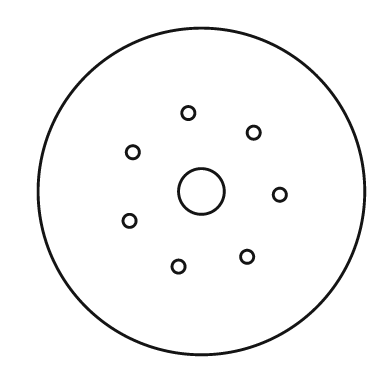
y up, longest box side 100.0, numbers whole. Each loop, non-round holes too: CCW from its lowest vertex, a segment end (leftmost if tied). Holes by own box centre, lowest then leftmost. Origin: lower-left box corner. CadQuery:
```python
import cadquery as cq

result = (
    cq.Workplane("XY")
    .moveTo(50.0, 50.0)
    .circle(50.0)
    .moveTo(43.0, 27.0)
    .circle(2.0)
    .moveTo(64.0, 30.0)
    .circle(2.0)
    .moveTo(28.0, 41.0)
    .circle(2.0)
    .moveTo(74.0, 49.0)
    .circle(2.0)
    .moveTo(50.0, 50.0)
    .circle(7.0)
    .moveTo(29.0, 62.0)
    .circle(2.0)
    .moveTo(66.0, 68.0)
    .circle(2.0)
    .moveTo(46.0, 74.0)
    .circle(2.0)
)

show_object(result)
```